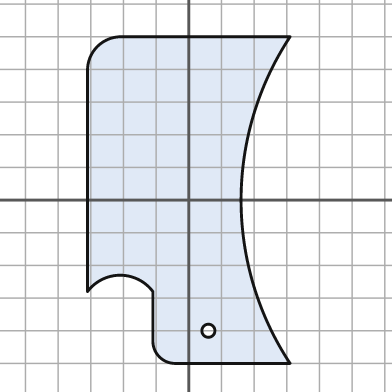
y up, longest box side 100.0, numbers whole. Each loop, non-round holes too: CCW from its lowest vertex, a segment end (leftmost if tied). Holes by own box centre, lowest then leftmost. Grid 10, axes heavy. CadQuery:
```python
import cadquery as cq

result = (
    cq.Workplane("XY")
    .moveTo(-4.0, -50.0)
    .lineTo(31.0, -50.0)
    .threePointArc((16.0, 0.0), (31.0, 50.0))
    .lineTo(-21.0, 50.0)
    .threePointArc((-28.0, 47.0), (-31.0, 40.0))
    .lineTo(-31.0, -28.0)
    .threePointArc((-21.0, -23.0), (-11.0, -28.0))
    .lineTo(-11.0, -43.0)
    .threePointArc((-9.0, -48.0), (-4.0, -50.0))
    .close()
    .moveTo(6.0, -40.0)
    .circle(2.0)
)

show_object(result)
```